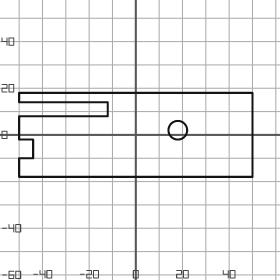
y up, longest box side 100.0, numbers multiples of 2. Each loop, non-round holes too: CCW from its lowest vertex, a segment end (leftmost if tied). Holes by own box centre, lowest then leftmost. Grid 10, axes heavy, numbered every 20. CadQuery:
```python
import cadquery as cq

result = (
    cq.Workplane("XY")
    .moveTo(-50.0, -18.0)
    .lineTo(50.0, -18.0)
    .lineTo(50.0, 18.0)
    .lineTo(-50.0, 18.0)
    .lineTo(-50.0, 14.0)
    .lineTo(-12.0, 14.0)
    .lineTo(-12.0, 8.0)
    .lineTo(-50.0, 8.0)
    .lineTo(-50.0, -2.0)
    .lineTo(-44.0, -2.0)
    .lineTo(-44.0, -10.0)
    .lineTo(-50.0, -10.0)
    .close()
    .moveTo(18.0, 2.0)
    .circle(4.0)
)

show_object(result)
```